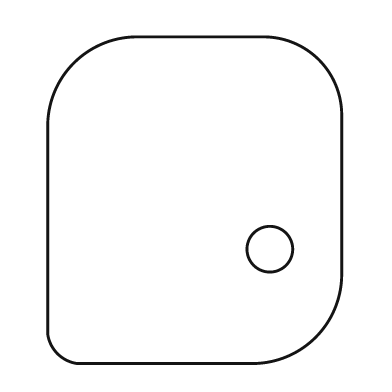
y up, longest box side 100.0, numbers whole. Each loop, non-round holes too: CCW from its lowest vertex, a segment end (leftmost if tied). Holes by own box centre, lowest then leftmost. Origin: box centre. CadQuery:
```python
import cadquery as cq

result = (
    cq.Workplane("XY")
    .moveTo(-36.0, -50.0)
    .lineTo(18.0, -50.0)
    .threePointArc((37.0, -42.0), (45.0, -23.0))
    .lineTo(45.0, 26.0)
    .threePointArc((38.0, 43.0), (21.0, 50.0))
    .lineTo(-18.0, 50.0)
    .threePointArc((-37.0, 42.0), (-45.0, 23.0))
    .lineTo(-45.0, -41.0)
    .threePointArc((-42.0, -47.0), (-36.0, -50.0))
    .close()
    .moveTo(23.0, -15.0)
    .circle(7.0)
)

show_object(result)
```